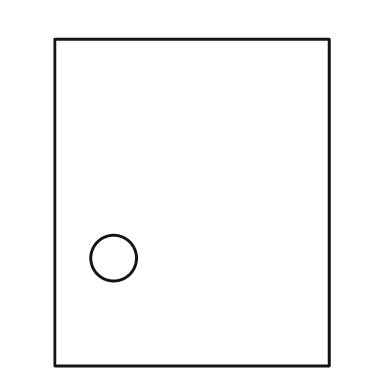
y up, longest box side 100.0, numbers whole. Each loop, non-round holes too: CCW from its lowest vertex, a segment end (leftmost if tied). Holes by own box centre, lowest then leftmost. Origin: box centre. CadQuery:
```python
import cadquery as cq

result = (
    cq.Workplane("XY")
    .moveTo(-42.0, -50.0)
    .lineTo(42.0, -50.0)
    .lineTo(42.0, 50.0)
    .lineTo(-42.0, 50.0)
    .close()
    .moveTo(-24.0, -17.0)
    .circle(7.0)
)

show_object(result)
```